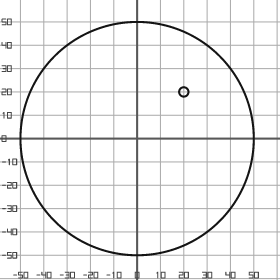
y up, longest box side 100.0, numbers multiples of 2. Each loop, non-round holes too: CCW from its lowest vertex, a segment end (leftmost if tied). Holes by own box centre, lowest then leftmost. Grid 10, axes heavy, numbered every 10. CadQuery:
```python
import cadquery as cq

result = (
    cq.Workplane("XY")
    .moveTo(0.0, 0.0)
    .circle(50.0)
    .moveTo(20.0, 20.0)
    .circle(2.0)
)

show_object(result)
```